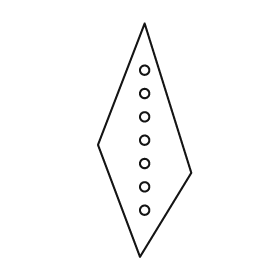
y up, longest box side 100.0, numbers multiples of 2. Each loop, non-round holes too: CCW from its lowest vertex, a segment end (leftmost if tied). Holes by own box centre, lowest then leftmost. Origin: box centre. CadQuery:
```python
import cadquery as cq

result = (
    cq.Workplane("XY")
    .moveTo(-2.0, -50.0)
    .lineTo(20.0, -14.0)
    .lineTo(0.0, 50.0)
    .lineTo(-20.0, -2.0)
    .close()
    .moveTo(0.0, -30.0)
    .circle(2.0)
    .moveTo(0.0, -20.0)
    .circle(2.0)
    .moveTo(0.0, -10.0)
    .circle(2.0)
    .moveTo(0.0, 0.0)
    .circle(2.0)
    .moveTo(0.0, 10.0)
    .circle(2.0)
    .moveTo(0.0, 20.0)
    .circle(2.0)
    .moveTo(0.0, 30.0)
    .circle(2.0)
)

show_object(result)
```